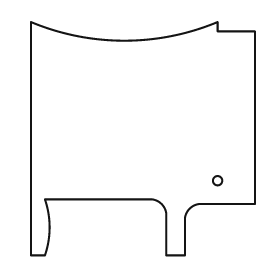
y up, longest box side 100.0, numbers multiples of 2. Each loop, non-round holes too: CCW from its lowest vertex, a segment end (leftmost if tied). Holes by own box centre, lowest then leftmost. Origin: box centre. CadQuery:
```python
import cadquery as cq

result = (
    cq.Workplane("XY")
    .moveTo(-48.0, -50.0)
    .lineTo(-42.0, -50.0)
    .threePointArc((-40.0, -38.0), (-42.0, -26.0))
    .lineTo(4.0, -26.0)
    .threePointArc((8.0, -28.0), (10.0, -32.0))
    .lineTo(10.0, -50.0)
    .lineTo(18.0, -50.0)
    .lineTo(18.0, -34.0)
    .threePointArc((20.0, -30.0), (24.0, -28.0))
    .lineTo(48.0, -28.0)
    .lineTo(48.0, 46.0)
    .lineTo(32.0, 46.0)
    .lineTo(32.0, 50.0)
    .threePointArc((-8.0, 42.0), (-48.0, 50.0))
    .close()
    .moveTo(32.0, -18.0)
    .circle(2.0)
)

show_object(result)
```